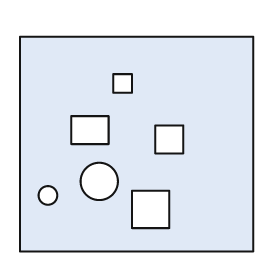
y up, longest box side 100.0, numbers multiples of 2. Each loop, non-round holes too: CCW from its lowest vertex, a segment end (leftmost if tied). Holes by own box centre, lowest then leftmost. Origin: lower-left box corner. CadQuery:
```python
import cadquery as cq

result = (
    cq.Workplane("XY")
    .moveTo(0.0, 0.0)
    .lineTo(100.0, 0.0)
    .lineTo(100.0, 92.0)
    .lineTo(0.0, 92.0)
    .close()
    .moveTo(48.0, 10.0)
    .lineTo(64.0, 10.0)
    .lineTo(64.0, 26.0)
    .lineTo(48.0, 26.0)
    .close()
    .moveTo(12.0, 24.0)
    .circle(4.0)
    .moveTo(34.0, 30.0)
    .circle(8.0)
    .moveTo(58.0, 42.0)
    .lineTo(70.0, 42.0)
    .lineTo(70.0, 54.0)
    .lineTo(58.0, 54.0)
    .close()
    .moveTo(22.0, 46.0)
    .lineTo(38.0, 46.0)
    .lineTo(38.0, 58.0)
    .lineTo(22.0, 58.0)
    .close()
    .moveTo(40.0, 68.0)
    .lineTo(48.0, 68.0)
    .lineTo(48.0, 76.0)
    .lineTo(40.0, 76.0)
    .close()
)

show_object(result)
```